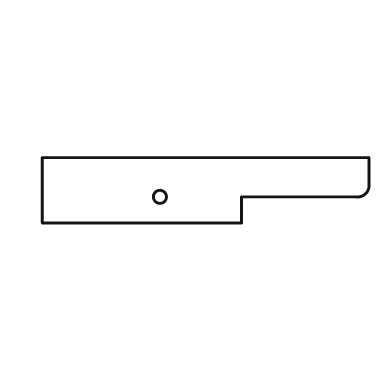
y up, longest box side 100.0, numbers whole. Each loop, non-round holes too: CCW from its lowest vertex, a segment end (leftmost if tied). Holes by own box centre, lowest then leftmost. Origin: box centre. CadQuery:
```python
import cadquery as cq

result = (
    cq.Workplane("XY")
    .moveTo(-50.0, -10.0)
    .lineTo(11.0, -10.0)
    .lineTo(11.0, -2.0)
    .lineTo(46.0, -2.0)
    .threePointArc((49.0, -1.0), (50.0, 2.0))
    .lineTo(50.0, 10.0)
    .lineTo(-50.0, 10.0)
    .close()
    .moveTo(-14.0, -2.0)
    .circle(2.0)
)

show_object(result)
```